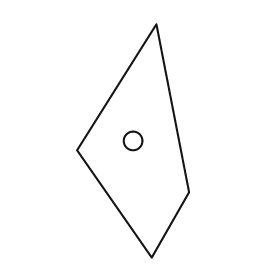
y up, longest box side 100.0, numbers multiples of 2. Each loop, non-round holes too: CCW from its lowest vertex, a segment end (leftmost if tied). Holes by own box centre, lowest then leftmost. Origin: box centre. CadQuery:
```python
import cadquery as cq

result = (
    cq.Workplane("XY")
    .moveTo(8.0, -50.0)
    .lineTo(24.0, -22.0)
    .lineTo(10.0, 50.0)
    .lineTo(-24.0, -4.0)
    .close()
    .moveTo(0.0, 0.0)
    .circle(4.0)
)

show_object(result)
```